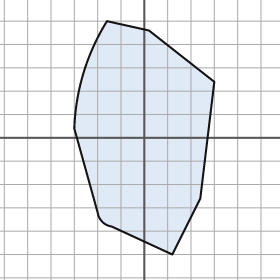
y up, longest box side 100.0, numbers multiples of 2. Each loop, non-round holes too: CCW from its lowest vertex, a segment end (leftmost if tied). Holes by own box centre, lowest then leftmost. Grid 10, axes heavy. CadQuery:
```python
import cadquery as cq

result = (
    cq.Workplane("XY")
    .moveTo(12.0, -50.0)
    .lineTo(24.0, -26.0)
    .lineTo(30.0, 24.0)
    .lineTo(2.0, 46.0)
    .lineTo(-16.0, 50.0)
    .threePointArc((-26.0, 28.0), (-30.0, 4.0))
    .lineTo(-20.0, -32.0)
    .threePointArc((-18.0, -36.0), (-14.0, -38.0))
    .close()
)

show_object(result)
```